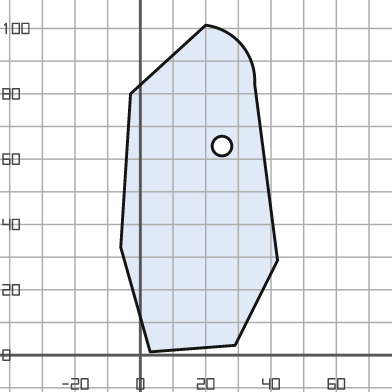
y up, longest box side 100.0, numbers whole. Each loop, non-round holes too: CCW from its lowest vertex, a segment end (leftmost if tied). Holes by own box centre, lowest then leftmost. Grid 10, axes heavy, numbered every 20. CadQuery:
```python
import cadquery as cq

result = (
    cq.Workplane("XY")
    .moveTo(3.0, 1.0)
    .lineTo(29.0, 3.0)
    .lineTo(42.0, 29.0)
    .lineTo(35.0, 83.0)
    .threePointArc((31.0, 95.0), (20.0, 101.0))
    .lineTo(-3.0, 80.0)
    .lineTo(-6.0, 33.0)
    .close()
    .moveTo(25.0, 64.0)
    .circle(3.0)
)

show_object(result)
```